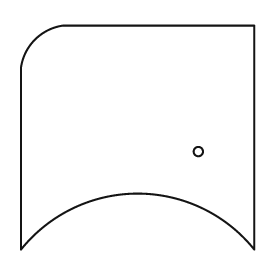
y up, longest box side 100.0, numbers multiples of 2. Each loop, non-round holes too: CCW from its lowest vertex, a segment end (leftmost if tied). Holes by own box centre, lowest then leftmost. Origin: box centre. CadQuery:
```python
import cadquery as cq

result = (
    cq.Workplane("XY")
    .moveTo(-50.0, -48.0)
    .threePointArc((0.0, -24.0), (50.0, -48.0))
    .lineTo(50.0, 48.0)
    .lineTo(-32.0, 48.0)
    .threePointArc((-44.0, 42.0), (-50.0, 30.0))
    .close()
    .moveTo(26.0, -6.0)
    .circle(2.0)
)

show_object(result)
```